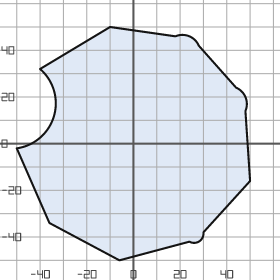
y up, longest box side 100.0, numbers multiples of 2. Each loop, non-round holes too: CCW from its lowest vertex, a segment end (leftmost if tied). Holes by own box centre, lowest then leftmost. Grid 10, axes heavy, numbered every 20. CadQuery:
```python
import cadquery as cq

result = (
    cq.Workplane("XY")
    .moveTo(-6.0, -50.0)
    .lineTo(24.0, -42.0)
    .threePointArc((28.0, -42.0), (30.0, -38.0))
    .lineTo(50.0, -16.0)
    .lineTo(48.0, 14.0)
    .threePointArc((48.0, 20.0), (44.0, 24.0))
    .lineTo(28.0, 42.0)
    .threePointArc((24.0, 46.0), (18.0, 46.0))
    .lineTo(-10.0, 50.0)
    .lineTo(-40.0, 32.0)
    .threePointArc((-34.0, 12.0), (-50.0, -2.0))
    .lineTo(-36.0, -34.0)
    .close()
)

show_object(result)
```